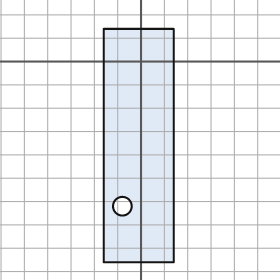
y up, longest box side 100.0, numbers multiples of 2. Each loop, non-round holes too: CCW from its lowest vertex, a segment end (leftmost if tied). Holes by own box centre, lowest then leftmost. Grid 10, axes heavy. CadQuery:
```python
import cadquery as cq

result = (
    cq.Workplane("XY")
    .moveTo(-16.0, -86.0)
    .lineTo(14.0, -86.0)
    .lineTo(14.0, 14.0)
    .lineTo(-16.0, 14.0)
    .close()
    .moveTo(-8.0, -62.0)
    .circle(4.0)
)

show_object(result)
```